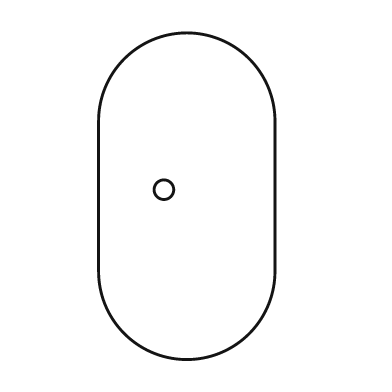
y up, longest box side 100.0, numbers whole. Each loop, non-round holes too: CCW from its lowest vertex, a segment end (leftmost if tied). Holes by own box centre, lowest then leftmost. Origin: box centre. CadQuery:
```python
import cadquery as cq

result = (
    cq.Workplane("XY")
    .moveTo(-27.0, -23.0)
    .threePointArc((0.0, -50.0), (27.0, -23.0))
    .lineTo(27.0, 23.0)
    .threePointArc((0.0, 50.0), (-27.0, 23.0))
    .close()
    .moveTo(-7.0, 2.0)
    .circle(3.0)
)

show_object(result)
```